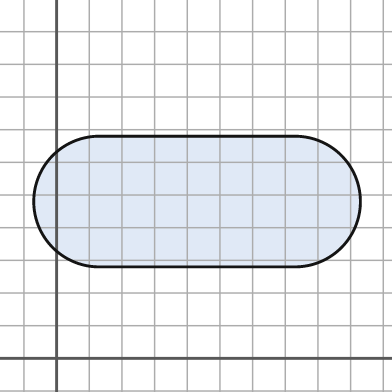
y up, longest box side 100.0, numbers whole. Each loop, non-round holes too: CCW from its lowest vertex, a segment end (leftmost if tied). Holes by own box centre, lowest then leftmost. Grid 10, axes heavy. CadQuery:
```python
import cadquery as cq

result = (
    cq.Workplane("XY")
    .moveTo(13.0, 28.0)
    .lineTo(73.0, 28.0)
    .threePointArc((93.0, 48.0), (73.0, 68.0))
    .lineTo(13.0, 68.0)
    .threePointArc((-7.0, 48.0), (13.0, 28.0))
    .close()
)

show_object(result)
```